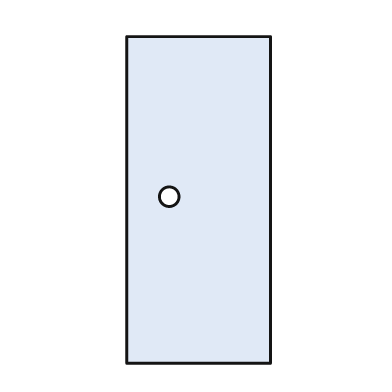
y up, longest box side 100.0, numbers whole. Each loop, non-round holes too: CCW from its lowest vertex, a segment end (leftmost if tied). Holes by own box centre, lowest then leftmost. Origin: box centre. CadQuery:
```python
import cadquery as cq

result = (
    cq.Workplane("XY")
    .moveTo(-22.0, -50.0)
    .lineTo(22.0, -50.0)
    .lineTo(22.0, 50.0)
    .lineTo(-22.0, 50.0)
    .close()
    .moveTo(-9.0, 1.0)
    .circle(3.0)
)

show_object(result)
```